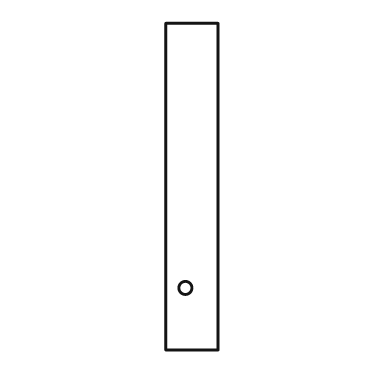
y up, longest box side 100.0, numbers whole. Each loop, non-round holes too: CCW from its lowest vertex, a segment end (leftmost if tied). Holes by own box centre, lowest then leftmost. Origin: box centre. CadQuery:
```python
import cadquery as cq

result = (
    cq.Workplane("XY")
    .moveTo(-8.0, -50.0)
    .lineTo(8.0, -50.0)
    .lineTo(8.0, 50.0)
    .lineTo(-8.0, 50.0)
    .close()
    .moveTo(-2.0, -31.0)
    .circle(2.0)
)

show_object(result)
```